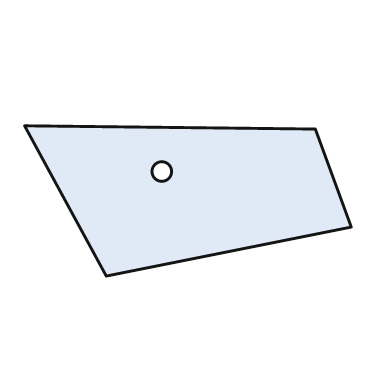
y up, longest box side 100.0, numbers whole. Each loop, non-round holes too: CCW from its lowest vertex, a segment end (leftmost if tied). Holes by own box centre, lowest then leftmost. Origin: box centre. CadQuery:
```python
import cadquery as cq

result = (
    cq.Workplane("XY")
    .moveTo(-25.0, -23.0)
    .lineTo(50.0, -8.0)
    .lineTo(39.0, 22.0)
    .lineTo(-50.0, 23.0)
    .close()
    .moveTo(-8.0, 9.0)
    .circle(3.0)
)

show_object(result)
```